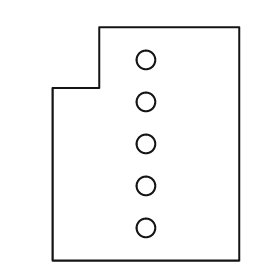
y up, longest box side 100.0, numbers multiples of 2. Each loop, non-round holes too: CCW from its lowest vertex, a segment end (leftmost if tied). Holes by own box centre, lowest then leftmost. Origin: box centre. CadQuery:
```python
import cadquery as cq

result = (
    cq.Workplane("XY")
    .moveTo(-40.0, -50.0)
    .lineTo(40.0, -50.0)
    .lineTo(40.0, 50.0)
    .lineTo(-20.0, 50.0)
    .lineTo(-20.0, 24.0)
    .lineTo(-40.0, 24.0)
    .close()
    .moveTo(0.0, -36.0)
    .circle(4.0)
    .moveTo(0.0, -18.0)
    .circle(4.0)
    .moveTo(0.0, 0.0)
    .circle(4.0)
    .moveTo(0.0, 18.0)
    .circle(4.0)
    .moveTo(0.0, 36.0)
    .circle(4.0)
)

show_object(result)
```